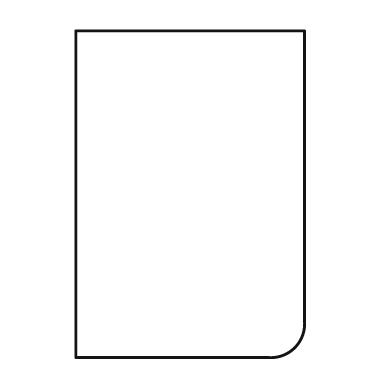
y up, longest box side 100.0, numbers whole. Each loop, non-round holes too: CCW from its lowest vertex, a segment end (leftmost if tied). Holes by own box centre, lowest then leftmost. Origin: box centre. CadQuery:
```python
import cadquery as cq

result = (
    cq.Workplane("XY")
    .moveTo(-35.0, -50.0)
    .lineTo(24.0, -50.0)
    .threePointArc((32.0, -47.0), (35.0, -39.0))
    .lineTo(35.0, 50.0)
    .lineTo(-35.0, 50.0)
    .close()
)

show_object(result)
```